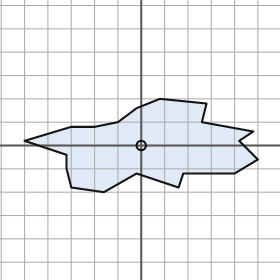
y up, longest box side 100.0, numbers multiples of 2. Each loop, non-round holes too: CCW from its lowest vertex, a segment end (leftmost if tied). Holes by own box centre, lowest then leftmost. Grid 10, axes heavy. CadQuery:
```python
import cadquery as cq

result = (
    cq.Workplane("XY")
    .moveTo(-16.0, -20.0)
    .lineTo(-2.0, -12.0)
    .lineTo(16.0, -18.0)
    .lineTo(18.0, -12.0)
    .lineTo(40.0, -12.0)
    .lineTo(50.0, -6.0)
    .lineTo(42.0, 2.0)
    .lineTo(48.0, 6.0)
    .lineTo(26.0, 10.0)
    .lineTo(28.0, 18.0)
    .lineTo(8.0, 20.0)
    .lineTo(-2.0, 16.0)
    .lineTo(-10.0, 10.0)
    .lineTo(-20.0, 8.0)
    .lineTo(-30.0, 8.0)
    .lineTo(-50.0, 2.0)
    .lineTo(-32.0, -4.0)
    .lineTo(-32.0, -10.0)
    .lineTo(-30.0, -18.0)
    .close()
    .moveTo(0.0, 0.0)
    .circle(2.0)
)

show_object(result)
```